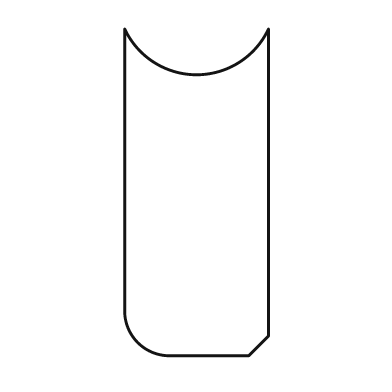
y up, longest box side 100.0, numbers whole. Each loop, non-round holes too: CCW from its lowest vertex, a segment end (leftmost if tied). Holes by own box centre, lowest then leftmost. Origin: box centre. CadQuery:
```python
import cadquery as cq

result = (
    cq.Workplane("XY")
    .moveTo(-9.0, -50.0)
    .lineTo(16.0, -50.0)
    .lineTo(22.0, -44.0)
    .lineTo(22.0, 50.0)
    .threePointArc((0.0, 36.0), (-22.0, 50.0))
    .lineTo(-22.0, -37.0)
    .threePointArc((-18.0, -46.0), (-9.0, -50.0))
    .close()
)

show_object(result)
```